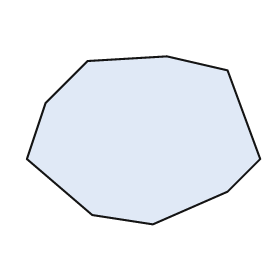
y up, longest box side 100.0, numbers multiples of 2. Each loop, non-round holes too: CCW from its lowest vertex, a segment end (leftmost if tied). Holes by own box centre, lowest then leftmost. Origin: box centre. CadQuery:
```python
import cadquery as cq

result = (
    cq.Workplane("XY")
    .moveTo(4.0, -36.0)
    .lineTo(36.0, -22.0)
    .lineTo(50.0, -8.0)
    .lineTo(36.0, 30.0)
    .lineTo(10.0, 36.0)
    .lineTo(-24.0, 34.0)
    .lineTo(-42.0, 16.0)
    .lineTo(-50.0, -8.0)
    .lineTo(-22.0, -32.0)
    .close()
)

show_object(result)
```